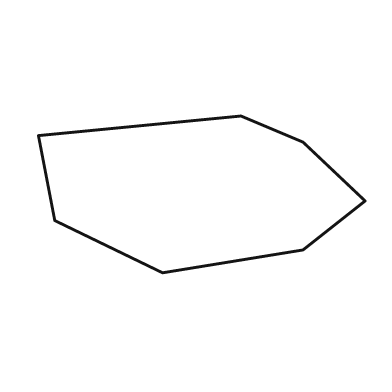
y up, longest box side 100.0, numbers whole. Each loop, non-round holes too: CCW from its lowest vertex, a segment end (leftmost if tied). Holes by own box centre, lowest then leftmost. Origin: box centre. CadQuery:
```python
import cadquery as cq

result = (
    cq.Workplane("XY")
    .moveTo(-12.0, -24.0)
    .lineTo(31.0, -17.0)
    .lineTo(50.0, -2.0)
    .lineTo(31.0, 16.0)
    .lineTo(12.0, 24.0)
    .lineTo(-50.0, 18.0)
    .lineTo(-45.0, -8.0)
    .close()
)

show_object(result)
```